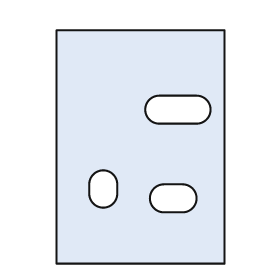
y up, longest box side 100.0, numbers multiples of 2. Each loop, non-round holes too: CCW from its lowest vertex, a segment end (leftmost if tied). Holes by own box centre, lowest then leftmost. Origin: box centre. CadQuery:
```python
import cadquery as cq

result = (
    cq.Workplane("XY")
    .moveTo(-36.0, -50.0)
    .lineTo(36.0, -50.0)
    .lineTo(36.0, 50.0)
    .lineTo(-36.0, 50.0)
    .close()
    .moveTo(10.0, -28.0)
    .lineTo(18.0, -28.0)
    .threePointArc((24.0, -22.0), (18.0, -16.0))
    .lineTo(10.0, -16.0)
    .threePointArc((4.0, -22.0), (10.0, -28.0))
    .close()
    .moveTo(-22.0, -20.0)
    .threePointArc((-16.0, -26.0), (-10.0, -20.0))
    .lineTo(-10.0, -16.0)
    .threePointArc((-16.0, -10.0), (-22.0, -16.0))
    .close()
    .moveTo(8.0, 10.0)
    .lineTo(24.0, 10.0)
    .threePointArc((30.0, 16.0), (24.0, 22.0))
    .lineTo(8.0, 22.0)
    .threePointArc((2.0, 16.0), (8.0, 10.0))
    .close()
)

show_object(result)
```